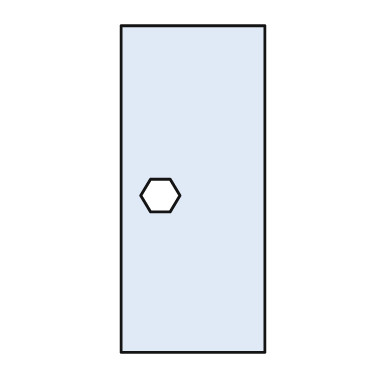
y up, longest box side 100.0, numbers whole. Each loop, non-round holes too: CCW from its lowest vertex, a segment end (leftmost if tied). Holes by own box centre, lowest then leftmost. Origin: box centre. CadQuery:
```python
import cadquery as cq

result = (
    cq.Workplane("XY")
    .moveTo(-22.0, -50.0)
    .lineTo(22.0, -50.0)
    .lineTo(22.0, 50.0)
    .lineTo(-22.0, 50.0)
    .close()
    .moveTo(-13.0, -7.0)
    .lineTo(-7.0, -7.0)
    .lineTo(-4.0, -2.0)
    .lineTo(-7.0, 3.0)
    .lineTo(-13.0, 3.0)
    .lineTo(-16.0, -2.0)
    .close()
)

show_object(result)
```